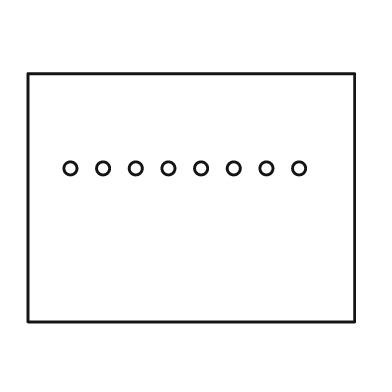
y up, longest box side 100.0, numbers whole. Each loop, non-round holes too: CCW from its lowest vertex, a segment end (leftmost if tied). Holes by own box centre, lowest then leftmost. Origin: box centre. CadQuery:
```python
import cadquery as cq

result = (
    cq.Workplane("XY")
    .moveTo(-50.0, -38.0)
    .lineTo(50.0, -38.0)
    .lineTo(50.0, 38.0)
    .lineTo(-50.0, 38.0)
    .close()
    .moveTo(-37.0, 9.0)
    .circle(2.0)
    .moveTo(-27.0, 9.0)
    .circle(2.0)
    .moveTo(-17.0, 9.0)
    .circle(2.0)
    .moveTo(-7.0, 9.0)
    .circle(2.0)
    .moveTo(3.0, 9.0)
    .circle(2.0)
    .moveTo(13.0, 9.0)
    .circle(2.0)
    .moveTo(23.0, 9.0)
    .circle(2.0)
    .moveTo(33.0, 9.0)
    .circle(2.0)
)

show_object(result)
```